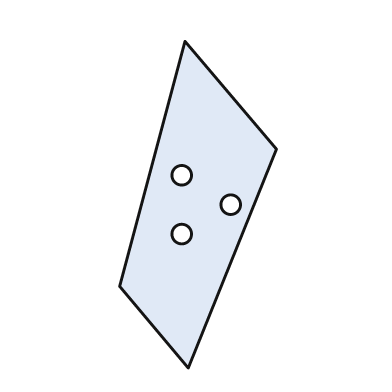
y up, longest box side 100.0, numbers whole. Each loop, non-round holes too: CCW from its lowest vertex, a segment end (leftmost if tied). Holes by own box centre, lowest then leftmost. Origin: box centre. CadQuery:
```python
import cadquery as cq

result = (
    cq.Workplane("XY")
    .moveTo(-3.0, -50.0)
    .lineTo(24.0, 17.0)
    .lineTo(-4.0, 50.0)
    .lineTo(-24.0, -25.0)
    .close()
    .moveTo(-5.0, -9.0)
    .circle(3.0)
    .moveTo(10.0, 0.0)
    .circle(3.0)
    .moveTo(-5.0, 9.0)
    .circle(3.0)
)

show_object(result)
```